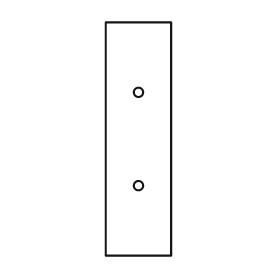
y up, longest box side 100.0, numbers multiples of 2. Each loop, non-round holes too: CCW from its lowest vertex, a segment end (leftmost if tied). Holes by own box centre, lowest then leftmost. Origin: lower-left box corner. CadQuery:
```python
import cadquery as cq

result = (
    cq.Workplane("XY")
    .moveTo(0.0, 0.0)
    .lineTo(28.0, 0.0)
    .lineTo(28.0, 100.0)
    .lineTo(0.0, 100.0)
    .close()
    .moveTo(14.0, 30.0)
    .circle(2.0)
    .moveTo(14.0, 70.0)
    .circle(2.0)
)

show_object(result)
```